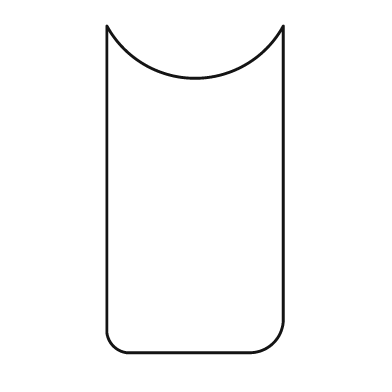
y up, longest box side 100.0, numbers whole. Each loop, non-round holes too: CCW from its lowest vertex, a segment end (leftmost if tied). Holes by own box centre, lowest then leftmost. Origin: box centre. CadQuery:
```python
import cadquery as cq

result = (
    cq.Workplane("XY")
    .moveTo(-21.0, -50.0)
    .lineTo(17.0, -50.0)
    .threePointArc((24.0, -47.0), (27.0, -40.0))
    .lineTo(27.0, 50.0)
    .threePointArc((0.0, 34.0), (-27.0, 50.0))
    .lineTo(-27.0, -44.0)
    .threePointArc((-25.0, -48.0), (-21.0, -50.0))
    .close()
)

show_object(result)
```